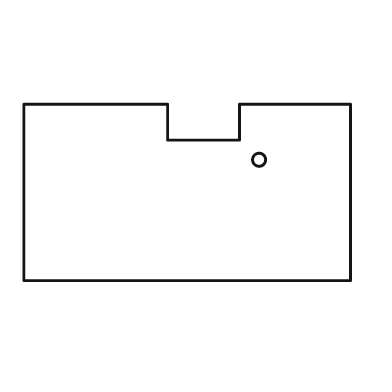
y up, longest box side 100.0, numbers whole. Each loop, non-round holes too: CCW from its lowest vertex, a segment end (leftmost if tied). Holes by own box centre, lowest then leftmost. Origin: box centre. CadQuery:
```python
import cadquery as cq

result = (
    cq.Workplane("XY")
    .moveTo(-50.0, -27.0)
    .lineTo(50.0, -27.0)
    .lineTo(50.0, 27.0)
    .lineTo(16.0, 27.0)
    .lineTo(16.0, 16.0)
    .lineTo(-6.0, 16.0)
    .lineTo(-6.0, 27.0)
    .lineTo(-50.0, 27.0)
    .close()
    .moveTo(22.0, 10.0)
    .circle(2.0)
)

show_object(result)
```